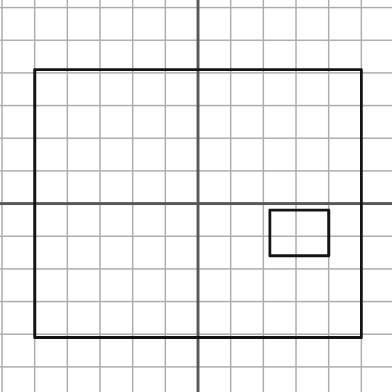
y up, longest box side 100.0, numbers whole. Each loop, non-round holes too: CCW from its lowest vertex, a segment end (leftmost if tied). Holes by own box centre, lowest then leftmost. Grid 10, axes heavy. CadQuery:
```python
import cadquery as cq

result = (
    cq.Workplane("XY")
    .moveTo(-50.0, -41.0)
    .lineTo(50.0, -41.0)
    .lineTo(50.0, 41.0)
    .lineTo(-50.0, 41.0)
    .close()
    .moveTo(22.0, -16.0)
    .lineTo(40.0, -16.0)
    .lineTo(40.0, -2.0)
    .lineTo(22.0, -2.0)
    .close()
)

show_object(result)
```